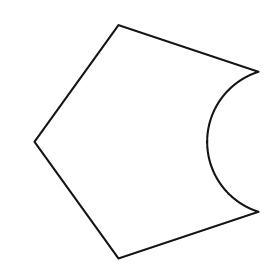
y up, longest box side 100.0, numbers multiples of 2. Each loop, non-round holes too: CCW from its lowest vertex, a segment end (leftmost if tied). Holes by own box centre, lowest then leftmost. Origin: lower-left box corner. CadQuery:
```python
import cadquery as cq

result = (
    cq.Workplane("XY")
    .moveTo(36.0, 0.0)
    .lineTo(96.0, 20.0)
    .threePointArc((74.0, 50.0), (96.0, 80.0))
    .lineTo(36.0, 100.0)
    .lineTo(0.0, 50.0)
    .close()
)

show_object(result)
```